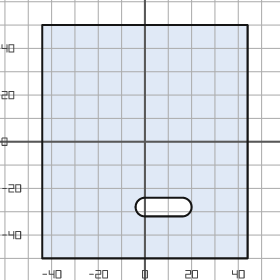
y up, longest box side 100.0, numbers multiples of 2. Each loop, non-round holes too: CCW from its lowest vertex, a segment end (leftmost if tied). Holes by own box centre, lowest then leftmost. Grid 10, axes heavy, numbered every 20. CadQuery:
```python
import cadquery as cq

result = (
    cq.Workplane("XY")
    .moveTo(-44.0, -50.0)
    .lineTo(44.0, -50.0)
    .lineTo(44.0, 50.0)
    .lineTo(-44.0, 50.0)
    .close()
    .moveTo(0.0, -32.0)
    .lineTo(16.0, -32.0)
    .threePointArc((20.0, -28.0), (16.0, -24.0))
    .lineTo(0.0, -24.0)
    .threePointArc((-4.0, -28.0), (0.0, -32.0))
    .close()
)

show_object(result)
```